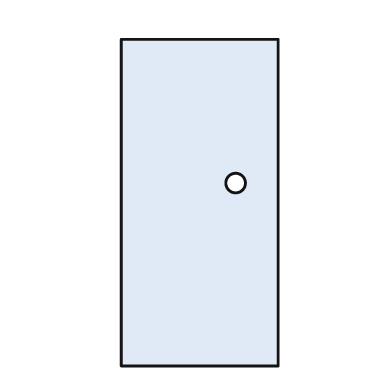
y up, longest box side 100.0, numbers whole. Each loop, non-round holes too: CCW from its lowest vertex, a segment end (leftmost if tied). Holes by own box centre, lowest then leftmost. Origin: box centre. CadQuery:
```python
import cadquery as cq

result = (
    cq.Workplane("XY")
    .moveTo(-24.0, -50.0)
    .lineTo(24.0, -50.0)
    .lineTo(24.0, 50.0)
    .lineTo(-24.0, 50.0)
    .close()
    .moveTo(11.0, 6.0)
    .circle(3.0)
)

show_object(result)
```